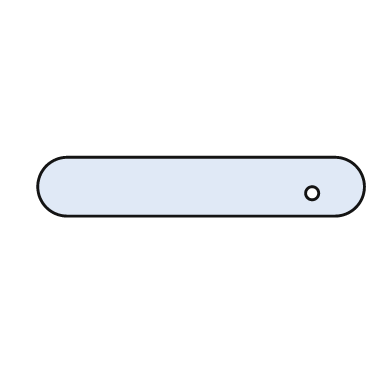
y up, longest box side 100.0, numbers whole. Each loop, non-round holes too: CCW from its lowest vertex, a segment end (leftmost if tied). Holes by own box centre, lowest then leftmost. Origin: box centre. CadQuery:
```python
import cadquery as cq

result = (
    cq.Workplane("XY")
    .moveTo(-41.0, -9.0)
    .lineTo(41.0, -9.0)
    .threePointArc((50.0, 0.0), (41.0, 9.0))
    .lineTo(-41.0, 9.0)
    .threePointArc((-50.0, 0.0), (-41.0, -9.0))
    .close()
    .moveTo(34.0, -2.0)
    .circle(2.0)
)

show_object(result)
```